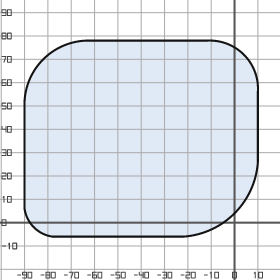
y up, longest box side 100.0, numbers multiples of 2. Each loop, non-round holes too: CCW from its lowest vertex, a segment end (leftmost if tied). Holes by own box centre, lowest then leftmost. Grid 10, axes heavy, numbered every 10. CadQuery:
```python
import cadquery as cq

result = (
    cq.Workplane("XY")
    .moveTo(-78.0, -6.0)
    .lineTo(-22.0, -6.0)
    .threePointArc((0.0, 4.0), (10.0, 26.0))
    .lineTo(10.0, 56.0)
    .threePointArc((4.0, 72.0), (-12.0, 78.0))
    .lineTo(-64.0, 78.0)
    .threePointArc((-82.0, 70.0), (-90.0, 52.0))
    .lineTo(-90.0, 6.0)
    .threePointArc((-86.0, -2.0), (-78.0, -6.0))
    .close()
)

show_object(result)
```